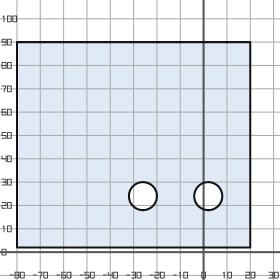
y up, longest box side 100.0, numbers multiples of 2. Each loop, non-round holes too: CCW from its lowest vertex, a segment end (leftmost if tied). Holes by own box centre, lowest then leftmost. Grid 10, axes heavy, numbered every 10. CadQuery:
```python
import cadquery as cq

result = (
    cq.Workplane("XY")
    .moveTo(-80.0, 2.0)
    .lineTo(20.0, 2.0)
    .lineTo(20.0, 90.0)
    .lineTo(-80.0, 90.0)
    .close()
    .moveTo(-26.0, 24.0)
    .circle(6.0)
    .moveTo(2.0, 24.0)
    .circle(6.0)
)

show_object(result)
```